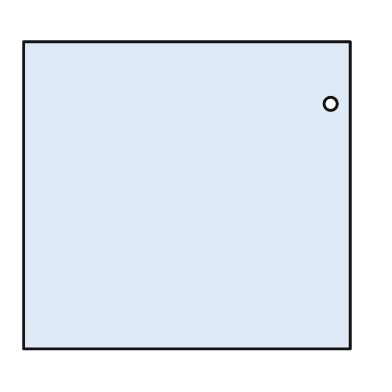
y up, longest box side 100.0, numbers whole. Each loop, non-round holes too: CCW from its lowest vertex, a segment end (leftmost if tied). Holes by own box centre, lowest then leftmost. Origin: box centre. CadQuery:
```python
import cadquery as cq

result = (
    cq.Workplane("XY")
    .moveTo(-50.0, -47.0)
    .lineTo(50.0, -47.0)
    .lineTo(50.0, 47.0)
    .lineTo(-50.0, 47.0)
    .close()
    .moveTo(44.0, 28.0)
    .circle(2.0)
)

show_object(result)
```